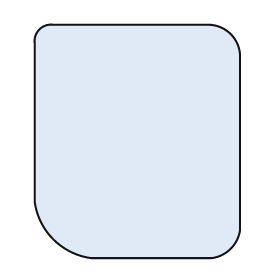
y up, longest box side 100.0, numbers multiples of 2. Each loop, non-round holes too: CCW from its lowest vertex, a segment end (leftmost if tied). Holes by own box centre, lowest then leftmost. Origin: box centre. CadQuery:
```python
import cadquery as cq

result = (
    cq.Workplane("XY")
    .moveTo(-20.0, -50.0)
    .lineTo(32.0, -50.0)
    .threePointArc((40.0, -46.0), (44.0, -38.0))
    .lineTo(44.0, 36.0)
    .threePointArc((40.0, 46.0), (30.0, 50.0))
    .lineTo(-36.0, 50.0)
    .threePointArc((-42.0, 48.0), (-44.0, 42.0))
    .lineTo(-44.0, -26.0)
    .threePointArc((-36.0, -42.0), (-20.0, -50.0))
    .close()
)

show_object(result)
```